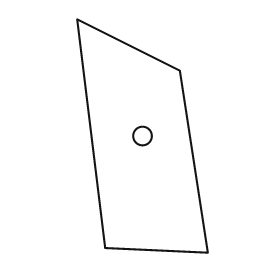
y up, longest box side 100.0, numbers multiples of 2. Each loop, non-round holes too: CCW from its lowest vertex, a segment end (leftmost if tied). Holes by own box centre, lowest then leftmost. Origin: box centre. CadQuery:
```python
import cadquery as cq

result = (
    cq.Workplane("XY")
    .moveTo(28.0, -50.0)
    .lineTo(16.0, 28.0)
    .lineTo(-28.0, 50.0)
    .lineTo(-16.0, -48.0)
    .close()
    .moveTo(0.0, 0.0)
    .circle(4.0)
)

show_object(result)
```